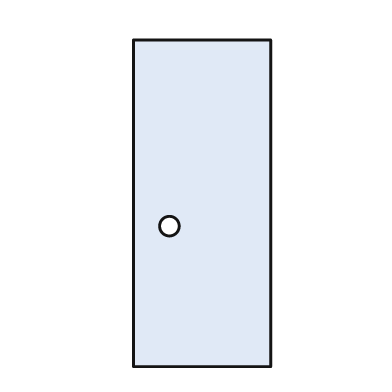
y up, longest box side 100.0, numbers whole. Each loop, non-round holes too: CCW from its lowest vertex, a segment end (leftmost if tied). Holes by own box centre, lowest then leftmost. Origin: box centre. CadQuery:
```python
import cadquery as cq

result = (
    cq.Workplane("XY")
    .moveTo(-21.0, -50.0)
    .lineTo(21.0, -50.0)
    .lineTo(21.0, 50.0)
    .lineTo(-21.0, 50.0)
    .close()
    .moveTo(-10.0, -7.0)
    .circle(3.0)
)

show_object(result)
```